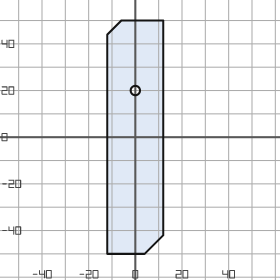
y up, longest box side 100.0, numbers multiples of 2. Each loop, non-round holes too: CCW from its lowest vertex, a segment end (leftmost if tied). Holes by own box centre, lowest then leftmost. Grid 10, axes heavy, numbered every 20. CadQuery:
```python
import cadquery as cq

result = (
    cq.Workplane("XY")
    .moveTo(-12.0, -50.0)
    .lineTo(4.0, -50.0)
    .lineTo(12.0, -42.0)
    .lineTo(12.0, 50.0)
    .lineTo(-6.0, 50.0)
    .lineTo(-12.0, 44.0)
    .close()
    .moveTo(0.0, 20.0)
    .circle(2.0)
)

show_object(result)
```